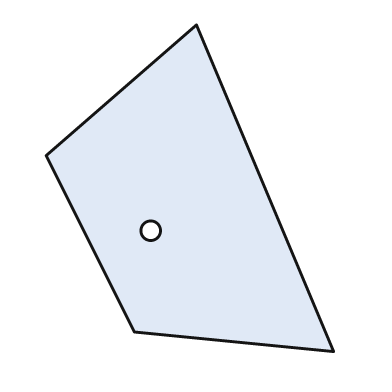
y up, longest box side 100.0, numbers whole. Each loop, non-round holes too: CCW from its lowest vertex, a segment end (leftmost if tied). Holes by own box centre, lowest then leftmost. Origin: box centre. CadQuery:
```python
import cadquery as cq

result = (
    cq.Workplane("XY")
    .moveTo(44.0, -50.0)
    .lineTo(2.0, 50.0)
    .lineTo(-44.0, 10.0)
    .lineTo(-17.0, -44.0)
    .close()
    .moveTo(-12.0, -13.0)
    .circle(3.0)
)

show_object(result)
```